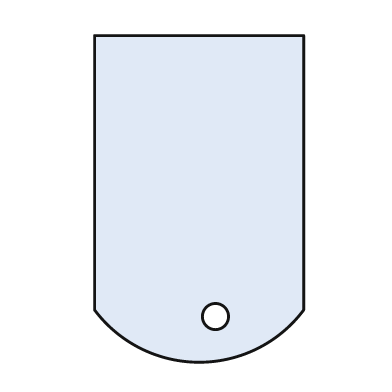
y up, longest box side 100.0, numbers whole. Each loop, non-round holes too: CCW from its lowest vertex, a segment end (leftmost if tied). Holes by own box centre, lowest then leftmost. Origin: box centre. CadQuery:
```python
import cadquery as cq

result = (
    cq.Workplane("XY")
    .moveTo(-32.0, -34.0)
    .threePointArc((0.0, -50.0), (32.0, -34.0))
    .lineTo(32.0, 50.0)
    .lineTo(-32.0, 50.0)
    .close()
    .moveTo(5.0, -36.0)
    .circle(4.0)
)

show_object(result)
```